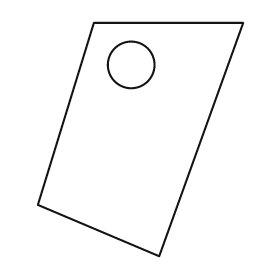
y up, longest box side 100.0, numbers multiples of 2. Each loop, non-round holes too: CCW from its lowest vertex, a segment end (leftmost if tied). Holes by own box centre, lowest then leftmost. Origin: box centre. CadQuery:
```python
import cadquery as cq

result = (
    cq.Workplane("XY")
    .moveTo(8.0, -50.0)
    .lineTo(44.0, 50.0)
    .lineTo(-20.0, 50.0)
    .lineTo(-44.0, -28.0)
    .close()
    .moveTo(-4.0, 32.0)
    .circle(10.0)
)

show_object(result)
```